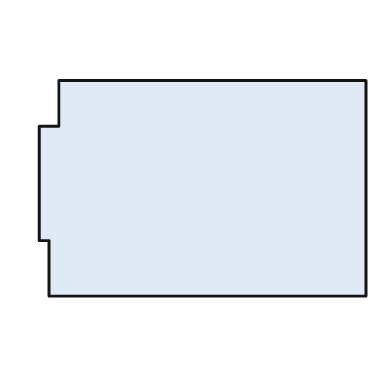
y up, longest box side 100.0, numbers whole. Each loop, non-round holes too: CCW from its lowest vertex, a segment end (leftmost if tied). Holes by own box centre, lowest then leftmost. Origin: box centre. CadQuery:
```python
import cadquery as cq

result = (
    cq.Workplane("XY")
    .moveTo(-47.0, -33.0)
    .lineTo(50.0, -33.0)
    .lineTo(50.0, 33.0)
    .lineTo(-44.0, 33.0)
    .lineTo(-44.0, 19.0)
    .lineTo(-50.0, 19.0)
    .lineTo(-50.0, -16.0)
    .lineTo(-47.0, -16.0)
    .close()
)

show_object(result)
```